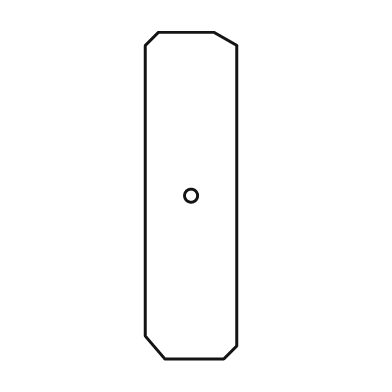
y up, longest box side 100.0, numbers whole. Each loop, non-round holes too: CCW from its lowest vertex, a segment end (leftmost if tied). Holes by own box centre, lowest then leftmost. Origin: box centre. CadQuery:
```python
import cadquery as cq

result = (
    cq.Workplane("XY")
    .moveTo(-8.0, -50.0)
    .lineTo(10.0, -50.0)
    .lineTo(14.0, -46.0)
    .lineTo(14.0, 46.0)
    .lineTo(7.0, 50.0)
    .lineTo(-10.0, 50.0)
    .lineTo(-14.0, 46.0)
    .lineTo(-14.0, -43.0)
    .close()
    .moveTo(0.0, 0.0)
    .circle(2.0)
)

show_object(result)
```